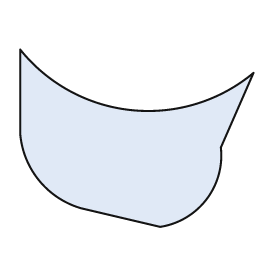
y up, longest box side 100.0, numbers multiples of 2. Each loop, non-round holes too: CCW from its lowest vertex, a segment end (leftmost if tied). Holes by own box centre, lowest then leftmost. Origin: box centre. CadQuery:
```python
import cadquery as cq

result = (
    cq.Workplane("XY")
    .moveTo(10.0, -38.0)
    .threePointArc((30.0, -26.0), (36.0, -4.0))
    .lineTo(50.0, 28.0)
    .threePointArc((-2.0, 12.0), (-50.0, 38.0))
    .lineTo(-50.0, 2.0)
    .threePointArc((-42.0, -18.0), (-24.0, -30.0))
    .close()
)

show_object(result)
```